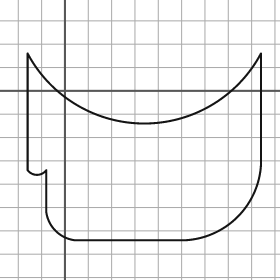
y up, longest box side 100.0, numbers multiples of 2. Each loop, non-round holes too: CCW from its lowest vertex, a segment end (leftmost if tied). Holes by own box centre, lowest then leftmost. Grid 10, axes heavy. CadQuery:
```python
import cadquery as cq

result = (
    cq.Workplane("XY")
    .moveTo(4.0, -64.0)
    .lineTo(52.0, -64.0)
    .threePointArc((74.0, -54.0), (84.0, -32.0))
    .lineTo(84.0, 16.0)
    .threePointArc((34.0, -14.0), (-16.0, 16.0))
    .lineTo(-16.0, -34.0)
    .threePointArc((-12.0, -36.0), (-8.0, -34.0))
    .lineTo(-8.0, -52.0)
    .threePointArc((-4.0, -60.0), (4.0, -64.0))
    .close()
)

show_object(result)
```